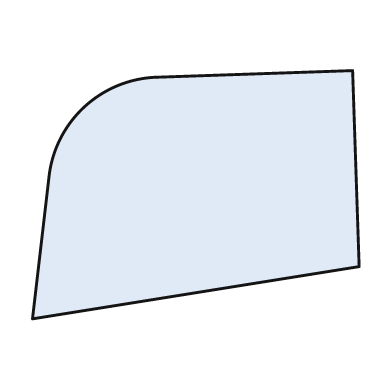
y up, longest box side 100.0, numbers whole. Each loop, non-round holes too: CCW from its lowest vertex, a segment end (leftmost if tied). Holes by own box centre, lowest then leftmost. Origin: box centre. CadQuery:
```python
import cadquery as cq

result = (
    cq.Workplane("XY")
    .moveTo(-50.0, -38.0)
    .lineTo(50.0, -22.0)
    .lineTo(48.0, 38.0)
    .lineTo(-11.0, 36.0)
    .threePointArc((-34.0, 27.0), (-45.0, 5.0))
    .close()
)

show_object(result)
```